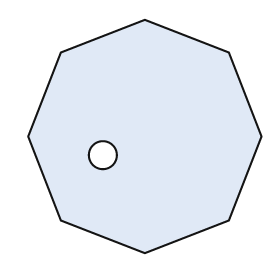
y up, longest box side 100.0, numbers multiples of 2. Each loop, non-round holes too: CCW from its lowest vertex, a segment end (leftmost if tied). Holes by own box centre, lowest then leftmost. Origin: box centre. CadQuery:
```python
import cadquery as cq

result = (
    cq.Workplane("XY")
    .moveTo(0.0, -50.0)
    .lineTo(36.0, -36.0)
    .lineTo(50.0, 0.0)
    .lineTo(36.0, 36.0)
    .lineTo(0.0, 50.0)
    .lineTo(-36.0, 36.0)
    .lineTo(-50.0, 0.0)
    .lineTo(-36.0, -36.0)
    .close()
    .moveTo(-18.0, -8.0)
    .circle(6.0)
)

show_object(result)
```